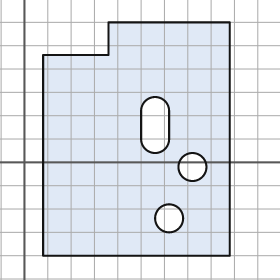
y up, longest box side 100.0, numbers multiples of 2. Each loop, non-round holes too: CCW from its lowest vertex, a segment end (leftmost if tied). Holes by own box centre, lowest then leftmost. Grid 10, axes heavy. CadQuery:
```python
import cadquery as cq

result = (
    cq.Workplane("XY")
    .moveTo(8.0, -40.0)
    .lineTo(88.0, -40.0)
    .lineTo(88.0, 60.0)
    .lineTo(36.0, 60.0)
    .lineTo(36.0, 46.0)
    .lineTo(8.0, 46.0)
    .close()
    .moveTo(62.0, -24.0)
    .circle(6.0)
    .moveTo(72.0, -2.0)
    .circle(6.0)
    .moveTo(50.0, 10.0)
    .threePointArc((56.0, 4.0), (62.0, 10.0))
    .lineTo(62.0, 22.0)
    .threePointArc((56.0, 28.0), (50.0, 22.0))
    .close()
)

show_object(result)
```